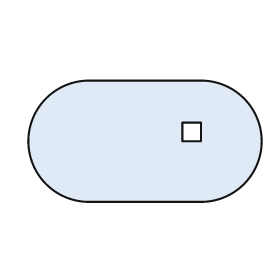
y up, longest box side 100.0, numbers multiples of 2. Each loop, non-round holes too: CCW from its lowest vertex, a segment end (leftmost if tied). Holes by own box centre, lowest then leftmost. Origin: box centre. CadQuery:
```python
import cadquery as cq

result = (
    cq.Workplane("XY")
    .moveTo(-24.0, -26.0)
    .lineTo(24.0, -26.0)
    .threePointArc((50.0, 0.0), (24.0, 26.0))
    .lineTo(-24.0, 26.0)
    .threePointArc((-50.0, 0.0), (-24.0, -26.0))
    .close()
    .moveTo(16.0, 0.0)
    .lineTo(24.0, 0.0)
    .lineTo(24.0, 8.0)
    .lineTo(16.0, 8.0)
    .close()
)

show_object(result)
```